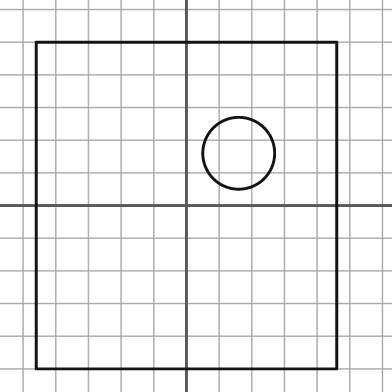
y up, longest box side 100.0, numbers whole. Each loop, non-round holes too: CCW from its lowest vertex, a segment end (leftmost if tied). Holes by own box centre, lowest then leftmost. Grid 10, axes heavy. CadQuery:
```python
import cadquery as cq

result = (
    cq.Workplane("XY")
    .moveTo(-46.0, -50.0)
    .lineTo(46.0, -50.0)
    .lineTo(46.0, 50.0)
    .lineTo(-46.0, 50.0)
    .close()
    .moveTo(16.0, 16.0)
    .circle(11.0)
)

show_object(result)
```